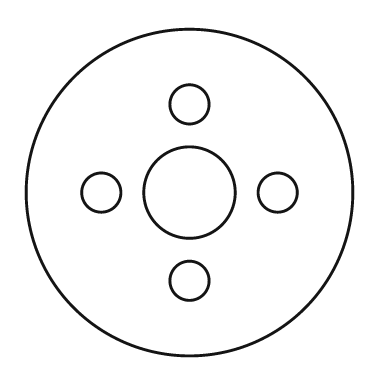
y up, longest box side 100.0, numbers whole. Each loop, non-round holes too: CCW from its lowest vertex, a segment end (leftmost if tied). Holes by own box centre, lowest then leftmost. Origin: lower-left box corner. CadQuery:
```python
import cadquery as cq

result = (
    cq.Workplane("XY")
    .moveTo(50.0, 50.0)
    .circle(50.0)
    .moveTo(50.0, 23.0)
    .circle(6.0)
    .moveTo(23.0, 50.0)
    .circle(6.0)
    .moveTo(50.0, 50.0)
    .circle(14.0)
    .moveTo(77.0, 50.0)
    .circle(6.0)
    .moveTo(50.0, 77.0)
    .circle(6.0)
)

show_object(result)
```